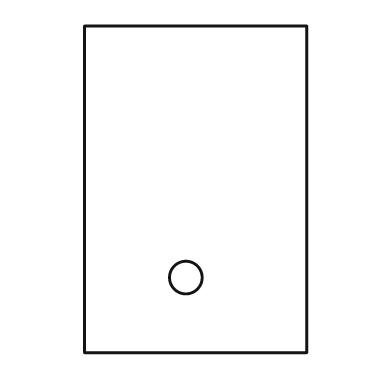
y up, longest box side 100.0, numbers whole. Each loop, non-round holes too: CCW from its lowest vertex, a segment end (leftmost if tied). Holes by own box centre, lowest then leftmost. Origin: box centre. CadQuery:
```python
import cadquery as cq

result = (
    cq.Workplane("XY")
    .moveTo(-34.0, -50.0)
    .lineTo(34.0, -50.0)
    .lineTo(34.0, 50.0)
    .lineTo(-34.0, 50.0)
    .close()
    .moveTo(-3.0, -27.0)
    .circle(5.0)
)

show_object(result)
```